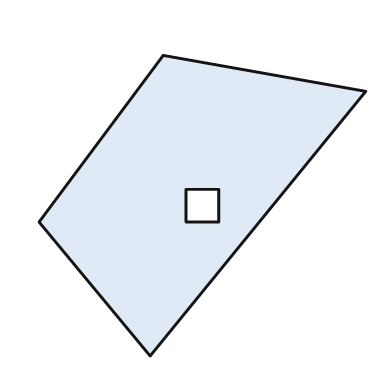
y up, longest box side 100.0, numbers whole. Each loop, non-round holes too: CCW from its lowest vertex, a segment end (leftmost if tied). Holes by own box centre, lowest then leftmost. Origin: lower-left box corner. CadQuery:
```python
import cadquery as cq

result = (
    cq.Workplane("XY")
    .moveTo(34.0, 0.0)
    .lineTo(100.0, 81.0)
    .lineTo(38.0, 92.0)
    .lineTo(0.0, 41.0)
    .close()
    .moveTo(45.0, 41.0)
    .lineTo(55.0, 41.0)
    .lineTo(55.0, 51.0)
    .lineTo(45.0, 51.0)
    .close()
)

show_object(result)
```